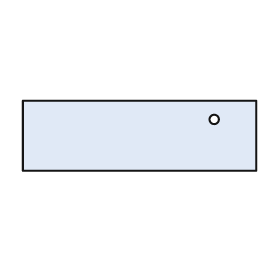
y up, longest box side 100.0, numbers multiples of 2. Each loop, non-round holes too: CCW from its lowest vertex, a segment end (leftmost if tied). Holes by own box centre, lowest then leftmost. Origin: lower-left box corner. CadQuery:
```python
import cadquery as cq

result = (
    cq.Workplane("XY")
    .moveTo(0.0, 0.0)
    .lineTo(100.0, 0.0)
    .lineTo(100.0, 30.0)
    .lineTo(0.0, 30.0)
    .close()
    .moveTo(82.0, 22.0)
    .circle(2.0)
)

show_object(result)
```